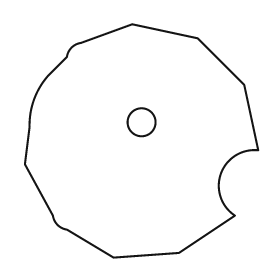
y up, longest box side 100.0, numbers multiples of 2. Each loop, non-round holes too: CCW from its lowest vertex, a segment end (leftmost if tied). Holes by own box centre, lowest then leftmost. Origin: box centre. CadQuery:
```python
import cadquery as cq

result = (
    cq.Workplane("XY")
    .moveTo(-12.0, -50.0)
    .lineTo(16.0, -48.0)
    .lineTo(40.0, -32.0)
    .threePointArc((34.0, -14.0), (50.0, -4.0))
    .lineTo(44.0, 24.0)
    .lineTo(24.0, 44.0)
    .lineTo(-4.0, 50.0)
    .lineTo(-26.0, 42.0)
    .threePointArc((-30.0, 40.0), (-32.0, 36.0))
    .lineTo(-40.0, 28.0)
    .threePointArc((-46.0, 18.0), (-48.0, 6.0))
    .lineTo(-50.0, -10.0)
    .lineTo(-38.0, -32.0)
    .threePointArc((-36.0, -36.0), (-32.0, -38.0))
    .close()
    .moveTo(0.0, 8.0)
    .circle(6.0)
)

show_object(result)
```